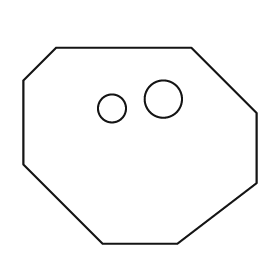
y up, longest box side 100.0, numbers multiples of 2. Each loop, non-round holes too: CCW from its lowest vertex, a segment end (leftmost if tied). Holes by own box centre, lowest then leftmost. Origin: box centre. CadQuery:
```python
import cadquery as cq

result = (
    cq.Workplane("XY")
    .moveTo(-16.0, -42.0)
    .lineTo(16.0, -42.0)
    .lineTo(50.0, -16.0)
    .lineTo(50.0, 14.0)
    .lineTo(22.0, 42.0)
    .lineTo(-36.0, 42.0)
    .lineTo(-50.0, 28.0)
    .lineTo(-50.0, -8.0)
    .close()
    .moveTo(-12.0, 16.0)
    .circle(6.0)
    .moveTo(10.0, 20.0)
    .circle(8.0)
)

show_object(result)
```